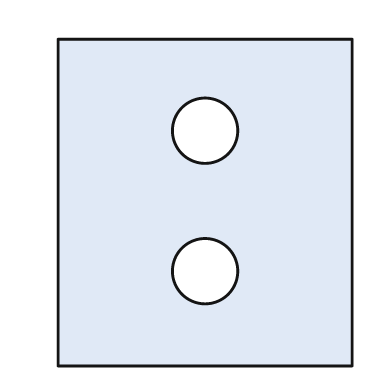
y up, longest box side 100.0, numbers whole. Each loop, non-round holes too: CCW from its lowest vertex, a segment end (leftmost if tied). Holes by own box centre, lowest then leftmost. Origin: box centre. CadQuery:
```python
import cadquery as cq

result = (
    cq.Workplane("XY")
    .moveTo(-45.0, -50.0)
    .lineTo(45.0, -50.0)
    .lineTo(45.0, 50.0)
    .lineTo(-45.0, 50.0)
    .close()
    .moveTo(0.0, -21.0)
    .circle(10.0)
    .moveTo(0.0, 22.0)
    .circle(10.0)
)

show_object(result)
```